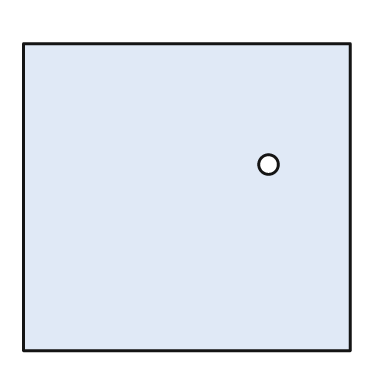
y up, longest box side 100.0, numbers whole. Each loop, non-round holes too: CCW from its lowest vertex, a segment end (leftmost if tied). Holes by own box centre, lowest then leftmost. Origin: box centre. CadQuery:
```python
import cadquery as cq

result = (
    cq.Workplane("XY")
    .moveTo(-50.0, -47.0)
    .lineTo(50.0, -47.0)
    .lineTo(50.0, 47.0)
    .lineTo(-50.0, 47.0)
    .close()
    .moveTo(25.0, 10.0)
    .circle(3.0)
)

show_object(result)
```